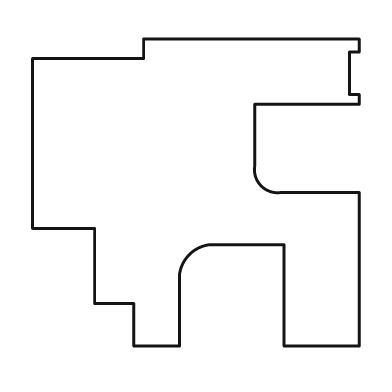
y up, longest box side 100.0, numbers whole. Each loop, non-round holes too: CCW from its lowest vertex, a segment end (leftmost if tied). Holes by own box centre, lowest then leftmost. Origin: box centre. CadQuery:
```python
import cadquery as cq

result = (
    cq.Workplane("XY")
    .moveTo(-19.0, -47.0)
    .lineTo(-5.0, -47.0)
    .lineTo(-5.0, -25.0)
    .threePointArc((-2.0, -19.0), (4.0, -16.0))
    .lineTo(27.0, -16.0)
    .lineTo(27.0, -47.0)
    .lineTo(50.0, -47.0)
    .lineTo(50.0, 0.0)
    .lineTo(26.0, 0.0)
    .threePointArc((20.0, 2.0), (18.0, 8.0))
    .lineTo(18.0, 27.0)
    .lineTo(50.0, 27.0)
    .lineTo(50.0, 30.0)
    .lineTo(47.0, 30.0)
    .lineTo(47.0, 43.0)
    .lineTo(50.0, 43.0)
    .lineTo(50.0, 47.0)
    .lineTo(-16.0, 47.0)
    .lineTo(-16.0, 41.0)
    .lineTo(-50.0, 41.0)
    .lineTo(-50.0, -11.0)
    .lineTo(-31.0, -11.0)
    .lineTo(-31.0, -34.0)
    .lineTo(-19.0, -34.0)
    .close()
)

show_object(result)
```